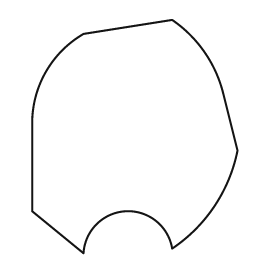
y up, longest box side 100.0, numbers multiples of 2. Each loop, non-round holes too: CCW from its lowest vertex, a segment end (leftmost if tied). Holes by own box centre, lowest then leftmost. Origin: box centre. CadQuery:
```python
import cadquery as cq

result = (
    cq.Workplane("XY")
    .moveTo(-22.0, -50.0)
    .threePointArc((-4.0, -32.0), (16.0, -48.0))
    .threePointArc((34.0, -30.0), (44.0, -6.0))
    .lineTo(38.0, 18.0)
    .threePointArc((30.0, 36.0), (16.0, 50.0))
    .lineTo(-22.0, 44.0)
    .threePointArc((-38.0, 28.0), (-44.0, 6.0))
    .lineTo(-44.0, -32.0)
    .close()
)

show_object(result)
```